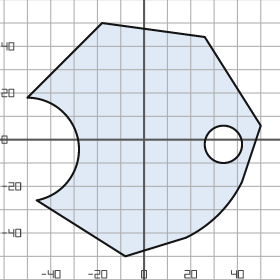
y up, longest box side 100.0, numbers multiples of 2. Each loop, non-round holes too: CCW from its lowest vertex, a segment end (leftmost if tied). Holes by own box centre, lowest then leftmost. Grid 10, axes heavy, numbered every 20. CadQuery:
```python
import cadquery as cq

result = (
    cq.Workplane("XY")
    .moveTo(-8.0, -50.0)
    .lineTo(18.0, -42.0)
    .threePointArc((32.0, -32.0), (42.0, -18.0))
    .lineTo(50.0, 6.0)
    .lineTo(26.0, 44.0)
    .lineTo(-18.0, 50.0)
    .lineTo(-50.0, 18.0)
    .threePointArc((-28.0, -2.0), (-46.0, -26.0))
    .close()
    .moveTo(34.0, -2.0)
    .circle(8.0)
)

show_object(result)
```